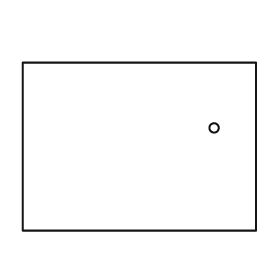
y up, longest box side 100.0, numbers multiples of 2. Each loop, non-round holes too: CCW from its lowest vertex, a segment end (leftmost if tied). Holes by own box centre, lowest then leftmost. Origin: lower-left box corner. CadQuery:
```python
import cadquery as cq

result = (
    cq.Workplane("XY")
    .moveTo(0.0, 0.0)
    .lineTo(100.0, 0.0)
    .lineTo(100.0, 72.0)
    .lineTo(0.0, 72.0)
    .close()
    .moveTo(82.0, 44.0)
    .circle(2.0)
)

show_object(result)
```